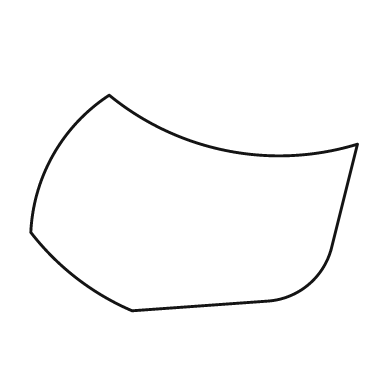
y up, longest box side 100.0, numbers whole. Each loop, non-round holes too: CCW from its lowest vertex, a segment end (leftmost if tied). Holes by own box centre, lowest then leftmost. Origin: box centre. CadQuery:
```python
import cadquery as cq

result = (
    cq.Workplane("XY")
    .moveTo(-19.0, -33.0)
    .lineTo(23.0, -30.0)
    .threePointArc((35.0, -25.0), (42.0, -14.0))
    .lineTo(50.0, 18.0)
    .threePointArc((10.0, 16.0), (-26.0, 33.0))
    .threePointArc((-43.0, 15.0), (-50.0, -9.0))
    .threePointArc((-36.0, -23.0), (-19.0, -33.0))
    .close()
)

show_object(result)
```